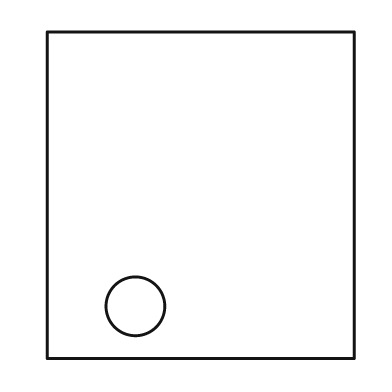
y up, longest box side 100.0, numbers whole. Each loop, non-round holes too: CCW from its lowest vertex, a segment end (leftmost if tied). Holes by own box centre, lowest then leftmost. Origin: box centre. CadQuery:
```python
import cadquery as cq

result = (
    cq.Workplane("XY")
    .moveTo(-47.0, -50.0)
    .lineTo(47.0, -50.0)
    .lineTo(47.0, 50.0)
    .lineTo(-47.0, 50.0)
    .close()
    .moveTo(-20.0, -34.0)
    .circle(9.0)
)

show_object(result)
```